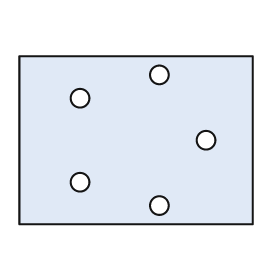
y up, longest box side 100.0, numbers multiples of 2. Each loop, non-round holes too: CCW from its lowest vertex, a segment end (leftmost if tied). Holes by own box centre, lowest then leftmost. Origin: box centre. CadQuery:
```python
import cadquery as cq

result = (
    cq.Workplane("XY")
    .moveTo(-50.0, -36.0)
    .lineTo(50.0, -36.0)
    .lineTo(50.0, 36.0)
    .lineTo(-50.0, 36.0)
    .close()
    .moveTo(10.0, -28.0)
    .circle(4.0)
    .moveTo(-24.0, -18.0)
    .circle(4.0)
    .moveTo(30.0, 0.0)
    .circle(4.0)
    .moveTo(-24.0, 18.0)
    .circle(4.0)
    .moveTo(10.0, 28.0)
    .circle(4.0)
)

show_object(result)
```